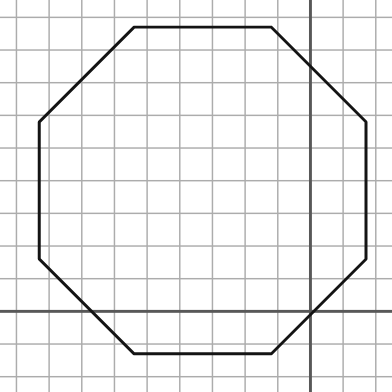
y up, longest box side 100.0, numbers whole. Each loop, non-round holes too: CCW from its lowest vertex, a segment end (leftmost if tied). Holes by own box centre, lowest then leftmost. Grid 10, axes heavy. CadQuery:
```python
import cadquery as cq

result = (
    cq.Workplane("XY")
    .moveTo(-54.0, -13.0)
    .lineTo(-12.0, -13.0)
    .lineTo(17.0, 16.0)
    .lineTo(17.0, 58.0)
    .lineTo(-12.0, 87.0)
    .lineTo(-54.0, 87.0)
    .lineTo(-83.0, 58.0)
    .lineTo(-83.0, 16.0)
    .close()
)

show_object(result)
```